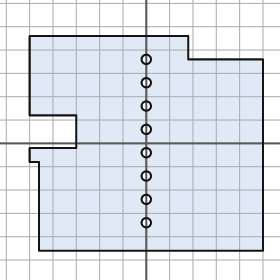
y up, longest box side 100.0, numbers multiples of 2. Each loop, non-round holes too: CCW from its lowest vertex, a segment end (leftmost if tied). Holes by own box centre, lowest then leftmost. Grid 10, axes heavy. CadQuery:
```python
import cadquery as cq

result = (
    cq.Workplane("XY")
    .moveTo(-46.0, -46.0)
    .lineTo(50.0, -46.0)
    .lineTo(50.0, 36.0)
    .lineTo(18.0, 36.0)
    .lineTo(18.0, 46.0)
    .lineTo(-50.0, 46.0)
    .lineTo(-50.0, 12.0)
    .lineTo(-30.0, 12.0)
    .lineTo(-30.0, -2.0)
    .lineTo(-50.0, -2.0)
    .lineTo(-50.0, -8.0)
    .lineTo(-46.0, -8.0)
    .close()
    .moveTo(0.0, -34.0)
    .circle(2.0)
    .moveTo(0.0, -24.0)
    .circle(2.0)
    .moveTo(0.0, -14.0)
    .circle(2.0)
    .moveTo(0.0, -4.0)
    .circle(2.0)
    .moveTo(0.0, 6.0)
    .circle(2.0)
    .moveTo(0.0, 16.0)
    .circle(2.0)
    .moveTo(0.0, 26.0)
    .circle(2.0)
    .moveTo(0.0, 36.0)
    .circle(2.0)
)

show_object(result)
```